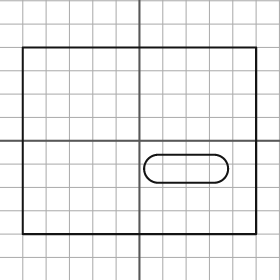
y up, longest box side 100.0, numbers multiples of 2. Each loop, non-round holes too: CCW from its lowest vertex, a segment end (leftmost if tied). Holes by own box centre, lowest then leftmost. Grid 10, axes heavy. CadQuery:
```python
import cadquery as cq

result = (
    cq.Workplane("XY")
    .moveTo(-50.0, -40.0)
    .lineTo(50.0, -40.0)
    .lineTo(50.0, 40.0)
    .lineTo(-50.0, 40.0)
    .close()
    .moveTo(8.0, -18.0)
    .lineTo(32.0, -18.0)
    .threePointArc((38.0, -12.0), (32.0, -6.0))
    .lineTo(8.0, -6.0)
    .threePointArc((2.0, -12.0), (8.0, -18.0))
    .close()
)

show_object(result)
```